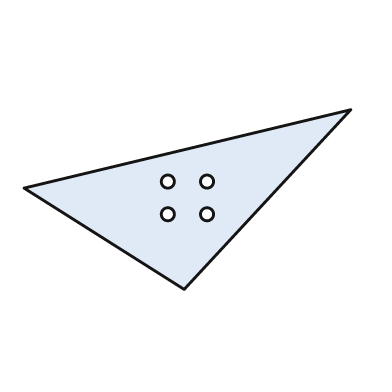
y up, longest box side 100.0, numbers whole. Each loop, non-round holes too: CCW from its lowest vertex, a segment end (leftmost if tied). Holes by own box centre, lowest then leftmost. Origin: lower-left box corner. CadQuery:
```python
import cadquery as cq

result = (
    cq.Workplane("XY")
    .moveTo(49.0, 0.0)
    .lineTo(100.0, 55.0)
    .lineTo(0.0, 31.0)
    .close()
    .moveTo(44.0, 23.0)
    .circle(2.0)
    .moveTo(56.0, 23.0)
    .circle(2.0)
    .moveTo(44.0, 33.0)
    .circle(2.0)
    .moveTo(56.0, 33.0)
    .circle(2.0)
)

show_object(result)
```